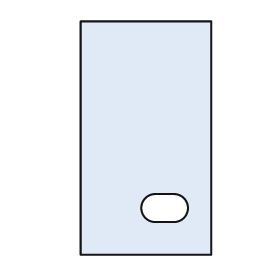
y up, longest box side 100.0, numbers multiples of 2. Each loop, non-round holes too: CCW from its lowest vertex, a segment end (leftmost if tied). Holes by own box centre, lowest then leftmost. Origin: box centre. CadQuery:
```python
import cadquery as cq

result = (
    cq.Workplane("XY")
    .moveTo(-28.0, -50.0)
    .lineTo(28.0, -50.0)
    .lineTo(28.0, 50.0)
    .lineTo(-28.0, 50.0)
    .close()
    .moveTo(4.0, -36.0)
    .lineTo(12.0, -36.0)
    .threePointArc((18.0, -30.0), (12.0, -24.0))
    .lineTo(4.0, -24.0)
    .threePointArc((-2.0, -30.0), (4.0, -36.0))
    .close()
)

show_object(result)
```